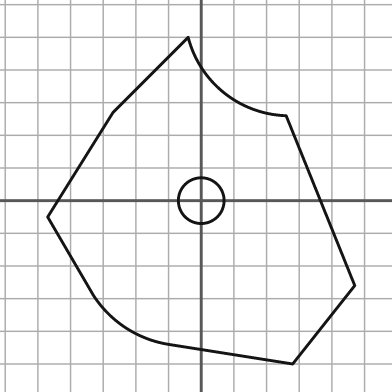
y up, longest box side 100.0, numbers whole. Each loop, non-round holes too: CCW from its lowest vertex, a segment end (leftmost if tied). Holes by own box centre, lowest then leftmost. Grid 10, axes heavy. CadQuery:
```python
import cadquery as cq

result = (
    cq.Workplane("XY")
    .moveTo(28.0, -50.0)
    .lineTo(47.0, -26.0)
    .lineTo(26.0, 26.0)
    .threePointArc((7.0, 33.0), (-4.0, 50.0))
    .lineTo(-27.0, 27.0)
    .lineTo(-47.0, -5.0)
    .lineTo(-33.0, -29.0)
    .threePointArc((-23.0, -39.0), (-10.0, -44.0))
    .close()
    .moveTo(0.0, 0.0)
    .circle(7.0)
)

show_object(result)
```